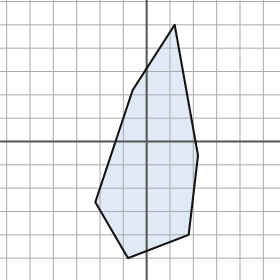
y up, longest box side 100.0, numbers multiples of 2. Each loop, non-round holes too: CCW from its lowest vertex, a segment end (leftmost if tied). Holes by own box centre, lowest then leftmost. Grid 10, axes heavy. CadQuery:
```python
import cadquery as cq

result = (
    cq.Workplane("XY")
    .moveTo(-8.0, -50.0)
    .lineTo(18.0, -40.0)
    .lineTo(22.0, -6.0)
    .lineTo(12.0, 50.0)
    .lineTo(-6.0, 22.0)
    .lineTo(-22.0, -26.0)
    .close()
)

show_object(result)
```